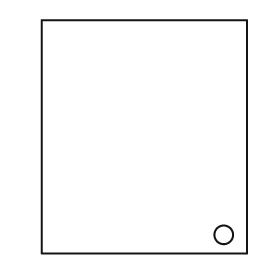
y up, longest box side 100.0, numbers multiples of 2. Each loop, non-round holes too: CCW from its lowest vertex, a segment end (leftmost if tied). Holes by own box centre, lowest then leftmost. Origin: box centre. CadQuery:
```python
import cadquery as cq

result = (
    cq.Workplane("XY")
    .moveTo(-44.0, -50.0)
    .lineTo(44.0, -50.0)
    .lineTo(44.0, 50.0)
    .lineTo(-44.0, 50.0)
    .close()
    .moveTo(34.0, -42.0)
    .circle(4.0)
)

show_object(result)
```